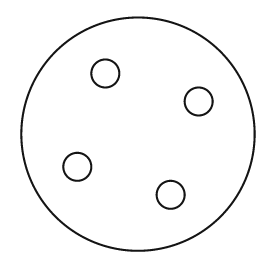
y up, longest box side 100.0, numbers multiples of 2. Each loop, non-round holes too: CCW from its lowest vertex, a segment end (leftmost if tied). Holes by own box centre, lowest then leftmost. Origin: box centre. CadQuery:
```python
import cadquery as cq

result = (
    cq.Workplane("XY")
    .moveTo(0.0, 0.0)
    .circle(50.0)
    .moveTo(14.0, -26.0)
    .circle(6.0)
    .moveTo(-26.0, -14.0)
    .circle(6.0)
    .moveTo(26.0, 14.0)
    .circle(6.0)
    .moveTo(-14.0, 26.0)
    .circle(6.0)
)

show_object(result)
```